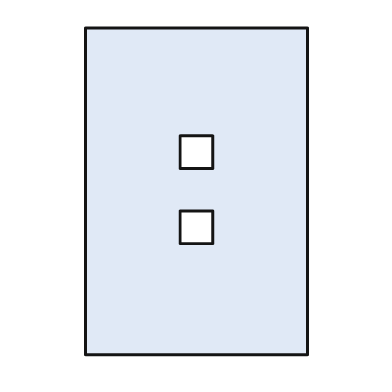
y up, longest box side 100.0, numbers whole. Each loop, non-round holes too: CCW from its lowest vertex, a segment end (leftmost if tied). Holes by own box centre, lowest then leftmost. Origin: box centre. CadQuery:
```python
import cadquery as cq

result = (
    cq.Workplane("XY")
    .moveTo(-34.0, -50.0)
    .lineTo(34.0, -50.0)
    .lineTo(34.0, 50.0)
    .lineTo(-34.0, 50.0)
    .close()
    .moveTo(-5.0, -16.0)
    .lineTo(5.0, -16.0)
    .lineTo(5.0, -6.0)
    .lineTo(-5.0, -6.0)
    .close()
    .moveTo(-5.0, 7.0)
    .lineTo(5.0, 7.0)
    .lineTo(5.0, 17.0)
    .lineTo(-5.0, 17.0)
    .close()
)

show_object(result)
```